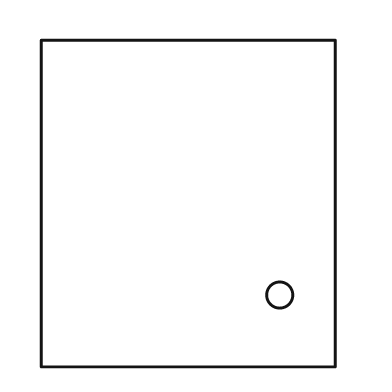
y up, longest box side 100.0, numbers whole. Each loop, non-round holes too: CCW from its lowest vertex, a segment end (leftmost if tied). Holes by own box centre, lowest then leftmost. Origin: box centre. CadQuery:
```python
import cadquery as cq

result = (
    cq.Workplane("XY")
    .moveTo(-45.0, -50.0)
    .lineTo(45.0, -50.0)
    .lineTo(45.0, 50.0)
    .lineTo(-45.0, 50.0)
    .close()
    .moveTo(28.0, -28.0)
    .circle(4.0)
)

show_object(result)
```